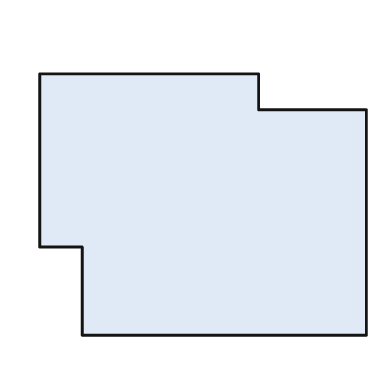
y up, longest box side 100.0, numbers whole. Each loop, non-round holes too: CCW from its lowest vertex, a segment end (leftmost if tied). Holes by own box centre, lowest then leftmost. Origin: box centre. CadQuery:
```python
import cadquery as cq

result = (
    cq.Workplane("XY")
    .moveTo(-37.0, -40.0)
    .lineTo(50.0, -40.0)
    .lineTo(50.0, 29.0)
    .lineTo(17.0, 29.0)
    .lineTo(17.0, 40.0)
    .lineTo(-50.0, 40.0)
    .lineTo(-50.0, -13.0)
    .lineTo(-37.0, -13.0)
    .close()
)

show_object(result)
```